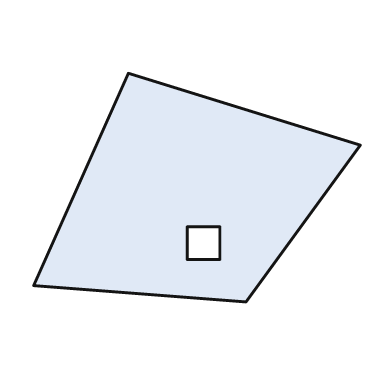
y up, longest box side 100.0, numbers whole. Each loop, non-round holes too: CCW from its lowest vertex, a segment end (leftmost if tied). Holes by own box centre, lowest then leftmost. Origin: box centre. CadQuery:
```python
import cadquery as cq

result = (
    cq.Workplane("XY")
    .moveTo(15.0, -35.0)
    .lineTo(50.0, 13.0)
    .lineTo(-21.0, 35.0)
    .lineTo(-50.0, -30.0)
    .close()
    .moveTo(-3.0, -22.0)
    .lineTo(7.0, -22.0)
    .lineTo(7.0, -12.0)
    .lineTo(-3.0, -12.0)
    .close()
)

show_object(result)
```